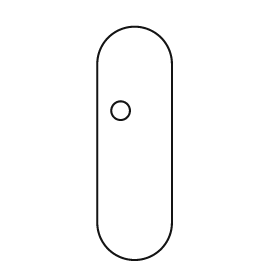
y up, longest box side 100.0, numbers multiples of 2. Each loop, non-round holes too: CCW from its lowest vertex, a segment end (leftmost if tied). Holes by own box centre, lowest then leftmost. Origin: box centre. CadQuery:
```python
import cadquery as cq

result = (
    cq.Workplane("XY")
    .moveTo(-16.0, -34.0)
    .threePointArc((0.0, -50.0), (16.0, -34.0))
    .lineTo(16.0, 34.0)
    .threePointArc((0.0, 50.0), (-16.0, 34.0))
    .close()
    .moveTo(-6.0, 14.0)
    .circle(4.0)
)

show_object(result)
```